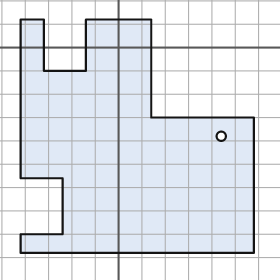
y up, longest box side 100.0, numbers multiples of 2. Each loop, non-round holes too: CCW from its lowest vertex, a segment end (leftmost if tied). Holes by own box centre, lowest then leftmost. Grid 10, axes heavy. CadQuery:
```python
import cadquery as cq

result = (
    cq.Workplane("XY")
    .moveTo(-42.0, -88.0)
    .lineTo(58.0, -88.0)
    .lineTo(58.0, -30.0)
    .lineTo(14.0, -30.0)
    .lineTo(14.0, 12.0)
    .lineTo(-14.0, 12.0)
    .lineTo(-14.0, -10.0)
    .lineTo(-32.0, -10.0)
    .lineTo(-32.0, 12.0)
    .lineTo(-42.0, 12.0)
    .lineTo(-42.0, -56.0)
    .lineTo(-24.0, -56.0)
    .lineTo(-24.0, -80.0)
    .lineTo(-42.0, -80.0)
    .close()
    .moveTo(44.0, -38.0)
    .circle(2.0)
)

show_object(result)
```